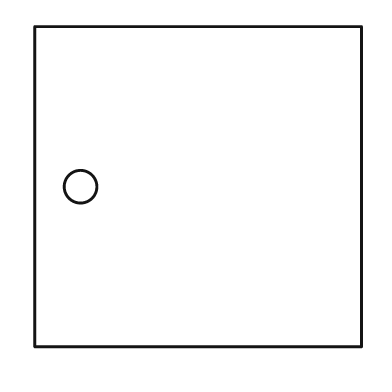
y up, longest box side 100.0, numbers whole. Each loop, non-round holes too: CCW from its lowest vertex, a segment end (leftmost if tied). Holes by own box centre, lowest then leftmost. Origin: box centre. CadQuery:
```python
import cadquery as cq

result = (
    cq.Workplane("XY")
    .moveTo(-50.0, -49.0)
    .lineTo(50.0, -49.0)
    .lineTo(50.0, 49.0)
    .lineTo(-50.0, 49.0)
    .close()
    .moveTo(-36.0, 0.0)
    .circle(5.0)
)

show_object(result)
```